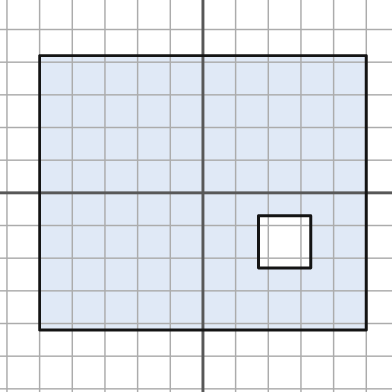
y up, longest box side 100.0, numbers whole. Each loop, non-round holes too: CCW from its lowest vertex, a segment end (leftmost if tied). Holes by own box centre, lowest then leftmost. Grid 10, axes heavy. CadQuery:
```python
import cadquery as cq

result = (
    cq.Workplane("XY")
    .moveTo(-50.0, -42.0)
    .lineTo(50.0, -42.0)
    .lineTo(50.0, 42.0)
    .lineTo(-50.0, 42.0)
    .close()
    .moveTo(17.0, -23.0)
    .lineTo(33.0, -23.0)
    .lineTo(33.0, -7.0)
    .lineTo(17.0, -7.0)
    .close()
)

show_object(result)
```